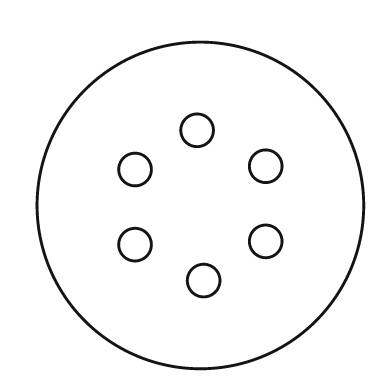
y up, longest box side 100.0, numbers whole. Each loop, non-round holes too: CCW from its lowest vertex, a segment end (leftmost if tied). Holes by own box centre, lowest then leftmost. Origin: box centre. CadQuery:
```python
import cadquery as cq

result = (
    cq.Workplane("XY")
    .moveTo(0.0, 0.0)
    .circle(50.0)
    .moveTo(1.0, -23.0)
    .circle(5.0)
    .moveTo(-20.0, -12.0)
    .circle(5.0)
    .moveTo(20.0, -11.0)
    .circle(5.0)
    .moveTo(-20.0, 11.0)
    .circle(5.0)
    .moveTo(20.0, 12.0)
    .circle(5.0)
    .moveTo(-1.0, 23.0)
    .circle(5.0)
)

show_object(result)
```